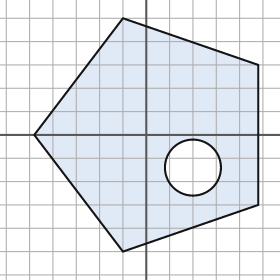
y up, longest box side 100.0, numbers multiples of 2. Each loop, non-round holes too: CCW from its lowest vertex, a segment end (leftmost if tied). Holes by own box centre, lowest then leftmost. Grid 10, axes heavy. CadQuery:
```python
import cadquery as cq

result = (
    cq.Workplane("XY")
    .moveTo(-10.0, -50.0)
    .lineTo(48.0, -30.0)
    .lineTo(48.0, 30.0)
    .lineTo(-10.0, 50.0)
    .lineTo(-48.0, 0.0)
    .close()
    .moveTo(20.0, -14.0)
    .circle(12.0)
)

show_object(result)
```